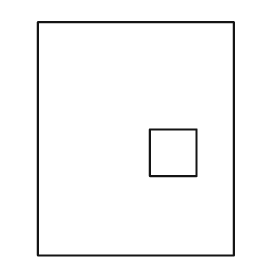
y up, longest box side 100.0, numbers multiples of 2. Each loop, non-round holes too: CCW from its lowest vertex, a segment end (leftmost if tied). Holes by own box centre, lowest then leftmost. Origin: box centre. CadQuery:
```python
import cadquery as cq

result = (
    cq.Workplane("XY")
    .moveTo(-42.0, -50.0)
    .lineTo(42.0, -50.0)
    .lineTo(42.0, 50.0)
    .lineTo(-42.0, 50.0)
    .close()
    .moveTo(6.0, -16.0)
    .lineTo(26.0, -16.0)
    .lineTo(26.0, 4.0)
    .lineTo(6.0, 4.0)
    .close()
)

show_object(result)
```